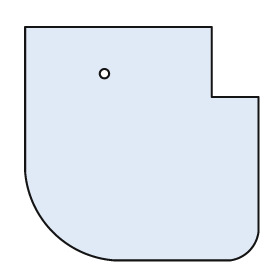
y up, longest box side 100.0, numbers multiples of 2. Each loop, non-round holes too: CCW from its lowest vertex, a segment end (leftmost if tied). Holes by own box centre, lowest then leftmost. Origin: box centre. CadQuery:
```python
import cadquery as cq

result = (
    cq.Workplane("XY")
    .moveTo(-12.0, -50.0)
    .lineTo(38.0, -50.0)
    .threePointArc((46.0, -46.0), (50.0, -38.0))
    .lineTo(50.0, 20.0)
    .lineTo(30.0, 20.0)
    .lineTo(30.0, 50.0)
    .lineTo(-50.0, 50.0)
    .lineTo(-50.0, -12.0)
    .threePointArc((-38.0, -38.0), (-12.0, -50.0))
    .close()
    .moveTo(-16.0, 30.0)
    .circle(2.0)
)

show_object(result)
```